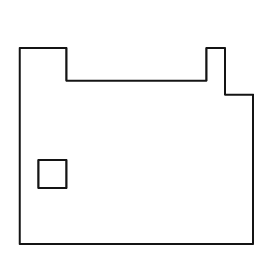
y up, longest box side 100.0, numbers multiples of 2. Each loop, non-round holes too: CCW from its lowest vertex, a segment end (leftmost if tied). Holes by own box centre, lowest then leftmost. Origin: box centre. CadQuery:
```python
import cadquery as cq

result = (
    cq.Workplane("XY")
    .moveTo(-50.0, -42.0)
    .lineTo(50.0, -42.0)
    .lineTo(50.0, 22.0)
    .lineTo(38.0, 22.0)
    .lineTo(38.0, 42.0)
    .lineTo(30.0, 42.0)
    .lineTo(30.0, 28.0)
    .lineTo(-30.0, 28.0)
    .lineTo(-30.0, 42.0)
    .lineTo(-50.0, 42.0)
    .close()
    .moveTo(-42.0, -18.0)
    .lineTo(-30.0, -18.0)
    .lineTo(-30.0, -6.0)
    .lineTo(-42.0, -6.0)
    .close()
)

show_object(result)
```